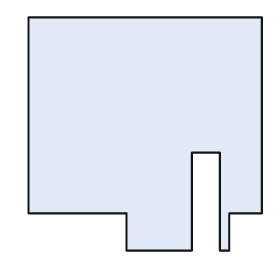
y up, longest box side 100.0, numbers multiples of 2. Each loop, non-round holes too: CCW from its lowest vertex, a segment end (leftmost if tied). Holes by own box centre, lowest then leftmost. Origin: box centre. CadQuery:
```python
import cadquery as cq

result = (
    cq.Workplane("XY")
    .moveTo(-8.0, -50.0)
    .lineTo(20.0, -50.0)
    .lineTo(20.0, -8.0)
    .lineTo(32.0, -8.0)
    .lineTo(32.0, -50.0)
    .lineTo(36.0, -50.0)
    .lineTo(36.0, -34.0)
    .lineTo(50.0, -34.0)
    .lineTo(50.0, 50.0)
    .lineTo(-50.0, 50.0)
    .lineTo(-50.0, -34.0)
    .lineTo(-8.0, -34.0)
    .close()
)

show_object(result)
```